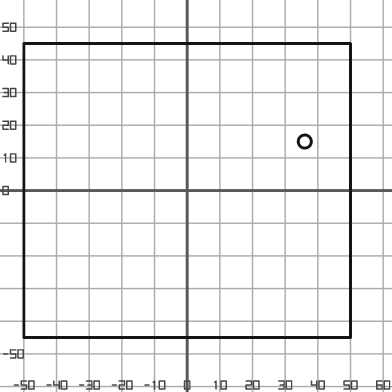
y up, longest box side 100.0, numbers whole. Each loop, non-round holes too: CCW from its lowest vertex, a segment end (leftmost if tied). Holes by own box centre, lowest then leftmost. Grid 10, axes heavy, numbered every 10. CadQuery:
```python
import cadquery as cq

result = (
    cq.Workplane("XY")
    .moveTo(-50.0, -45.0)
    .lineTo(50.0, -45.0)
    .lineTo(50.0, 45.0)
    .lineTo(-50.0, 45.0)
    .close()
    .moveTo(36.0, 15.0)
    .circle(2.0)
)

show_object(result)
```